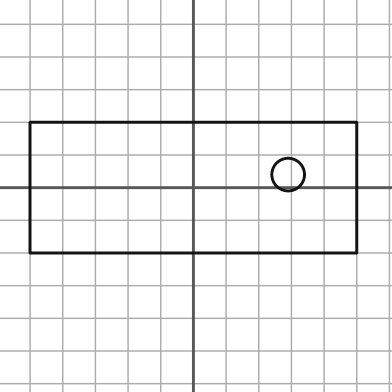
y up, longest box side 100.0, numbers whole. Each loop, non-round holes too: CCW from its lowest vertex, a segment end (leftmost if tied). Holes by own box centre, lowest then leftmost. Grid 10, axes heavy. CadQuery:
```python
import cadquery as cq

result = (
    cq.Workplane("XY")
    .moveTo(-50.0, -20.0)
    .lineTo(50.0, -20.0)
    .lineTo(50.0, 20.0)
    .lineTo(-50.0, 20.0)
    .close()
    .moveTo(29.0, 4.0)
    .circle(5.0)
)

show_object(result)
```